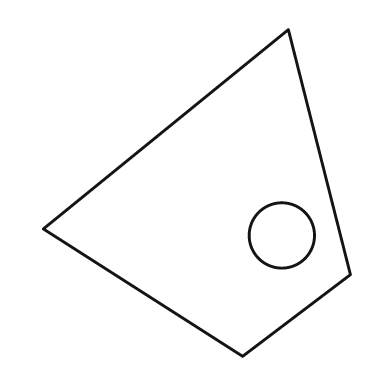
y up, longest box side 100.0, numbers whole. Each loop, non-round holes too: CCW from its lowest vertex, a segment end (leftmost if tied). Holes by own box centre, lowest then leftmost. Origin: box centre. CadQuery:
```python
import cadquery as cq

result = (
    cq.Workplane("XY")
    .moveTo(14.0, -50.0)
    .lineTo(47.0, -25.0)
    .lineTo(28.0, 50.0)
    .lineTo(-47.0, -11.0)
    .close()
    .moveTo(26.0, -13.0)
    .circle(10.0)
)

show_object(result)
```